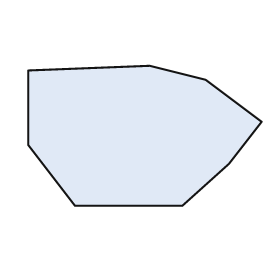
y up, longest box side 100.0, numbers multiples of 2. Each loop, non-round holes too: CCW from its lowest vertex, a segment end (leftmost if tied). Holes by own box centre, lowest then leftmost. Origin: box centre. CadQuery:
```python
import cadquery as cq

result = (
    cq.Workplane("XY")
    .moveTo(-30.0, -30.0)
    .lineTo(16.0, -30.0)
    .lineTo(36.0, -12.0)
    .lineTo(50.0, 6.0)
    .lineTo(26.0, 24.0)
    .lineTo(2.0, 30.0)
    .lineTo(-50.0, 28.0)
    .lineTo(-50.0, -4.0)
    .close()
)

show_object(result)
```